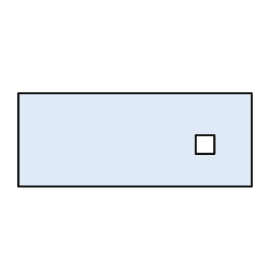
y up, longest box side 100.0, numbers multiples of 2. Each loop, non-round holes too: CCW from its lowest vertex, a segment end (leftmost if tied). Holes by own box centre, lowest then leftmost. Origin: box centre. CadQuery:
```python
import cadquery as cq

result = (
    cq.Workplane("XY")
    .moveTo(-50.0, -20.0)
    .lineTo(50.0, -20.0)
    .lineTo(50.0, 20.0)
    .lineTo(-50.0, 20.0)
    .close()
    .moveTo(26.0, -6.0)
    .lineTo(34.0, -6.0)
    .lineTo(34.0, 2.0)
    .lineTo(26.0, 2.0)
    .close()
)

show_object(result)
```